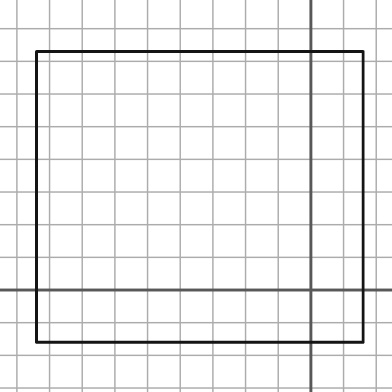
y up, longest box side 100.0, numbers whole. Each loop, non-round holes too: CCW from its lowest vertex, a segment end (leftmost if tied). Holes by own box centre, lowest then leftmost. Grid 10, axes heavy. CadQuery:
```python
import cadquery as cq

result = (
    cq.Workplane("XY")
    .moveTo(-84.0, -16.0)
    .lineTo(16.0, -16.0)
    .lineTo(16.0, 73.0)
    .lineTo(-84.0, 73.0)
    .close()
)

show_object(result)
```